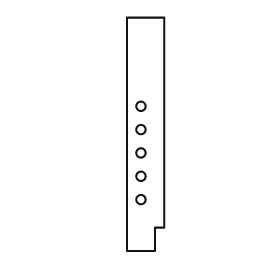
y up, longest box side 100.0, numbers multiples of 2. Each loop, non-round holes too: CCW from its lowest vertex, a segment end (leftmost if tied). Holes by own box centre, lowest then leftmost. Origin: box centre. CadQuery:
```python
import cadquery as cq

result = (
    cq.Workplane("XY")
    .moveTo(-8.0, -50.0)
    .lineTo(4.0, -50.0)
    .lineTo(4.0, -40.0)
    .lineTo(8.0, -40.0)
    .lineTo(8.0, 50.0)
    .lineTo(-8.0, 50.0)
    .close()
    .moveTo(-2.0, -28.0)
    .circle(2.0)
    .moveTo(-2.0, -18.0)
    .circle(2.0)
    .moveTo(-2.0, -8.0)
    .circle(2.0)
    .moveTo(-2.0, 2.0)
    .circle(2.0)
    .moveTo(-2.0, 12.0)
    .circle(2.0)
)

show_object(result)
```